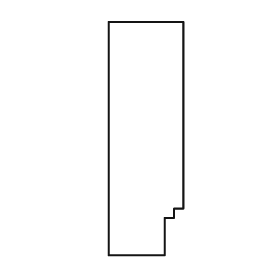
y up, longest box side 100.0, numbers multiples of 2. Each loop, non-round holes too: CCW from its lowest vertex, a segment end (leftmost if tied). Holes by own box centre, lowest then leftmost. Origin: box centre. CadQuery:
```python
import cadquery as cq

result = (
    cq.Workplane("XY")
    .moveTo(-16.0, -50.0)
    .lineTo(8.0, -50.0)
    .lineTo(8.0, -34.0)
    .lineTo(12.0, -34.0)
    .lineTo(12.0, -30.0)
    .lineTo(16.0, -30.0)
    .lineTo(16.0, 50.0)
    .lineTo(-16.0, 50.0)
    .close()
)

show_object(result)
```